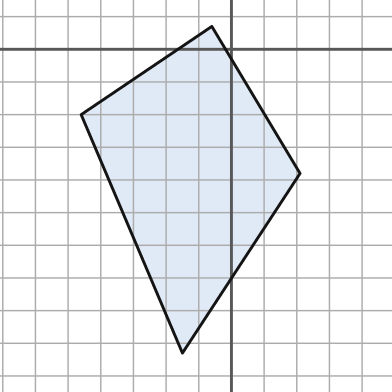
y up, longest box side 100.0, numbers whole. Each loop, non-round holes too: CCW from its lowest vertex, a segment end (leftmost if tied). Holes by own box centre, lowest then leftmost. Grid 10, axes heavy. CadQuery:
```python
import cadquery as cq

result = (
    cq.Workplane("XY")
    .moveTo(-15.0, -93.0)
    .lineTo(21.0, -38.0)
    .lineTo(-6.0, 7.0)
    .lineTo(-46.0, -20.0)
    .close()
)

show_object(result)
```